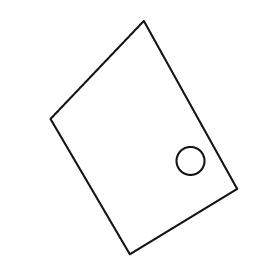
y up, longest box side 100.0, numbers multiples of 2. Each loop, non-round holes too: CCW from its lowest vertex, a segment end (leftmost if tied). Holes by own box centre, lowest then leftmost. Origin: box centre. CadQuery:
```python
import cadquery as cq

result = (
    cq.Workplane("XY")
    .moveTo(-6.0, -50.0)
    .lineTo(40.0, -22.0)
    .lineTo(0.0, 50.0)
    .lineTo(-40.0, 8.0)
    .close()
    .moveTo(20.0, -10.0)
    .circle(6.0)
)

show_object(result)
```